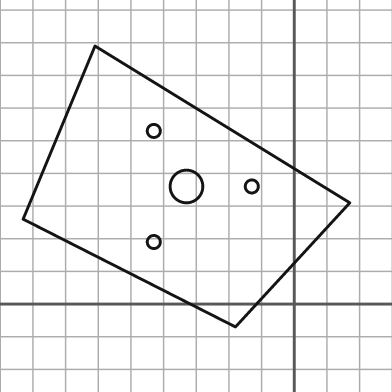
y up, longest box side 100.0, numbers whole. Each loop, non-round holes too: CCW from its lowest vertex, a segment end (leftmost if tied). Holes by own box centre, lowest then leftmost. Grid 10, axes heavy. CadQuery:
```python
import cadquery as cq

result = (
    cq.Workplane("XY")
    .moveTo(-18.0, -7.0)
    .lineTo(17.0, 31.0)
    .lineTo(-61.0, 79.0)
    .lineTo(-83.0, 26.0)
    .close()
    .moveTo(-43.0, 19.0)
    .circle(2.0)
    .moveTo(-33.0, 36.0)
    .circle(5.0)
    .moveTo(-13.0, 36.0)
    .circle(2.0)
    .moveTo(-43.0, 53.0)
    .circle(2.0)
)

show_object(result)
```